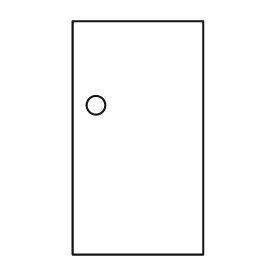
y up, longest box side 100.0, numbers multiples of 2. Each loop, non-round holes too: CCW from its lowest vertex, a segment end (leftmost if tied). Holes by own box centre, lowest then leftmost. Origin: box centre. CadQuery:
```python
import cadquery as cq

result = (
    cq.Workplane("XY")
    .moveTo(-28.0, -50.0)
    .lineTo(28.0, -50.0)
    .lineTo(28.0, 50.0)
    .lineTo(-28.0, 50.0)
    .close()
    .moveTo(-18.0, 14.0)
    .circle(4.0)
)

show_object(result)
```